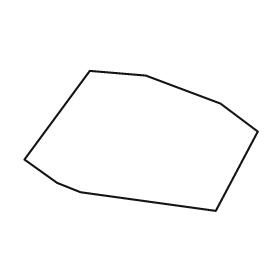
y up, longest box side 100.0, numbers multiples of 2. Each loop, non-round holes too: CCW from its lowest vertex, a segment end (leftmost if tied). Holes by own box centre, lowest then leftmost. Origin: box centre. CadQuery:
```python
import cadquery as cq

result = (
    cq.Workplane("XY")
    .moveTo(32.0, -30.0)
    .lineTo(50.0, 4.0)
    .lineTo(34.0, 16.0)
    .lineTo(2.0, 28.0)
    .lineTo(-22.0, 30.0)
    .lineTo(-50.0, -8.0)
    .lineTo(-36.0, -18.0)
    .lineTo(-26.0, -22.0)
    .close()
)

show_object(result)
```